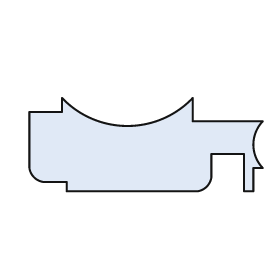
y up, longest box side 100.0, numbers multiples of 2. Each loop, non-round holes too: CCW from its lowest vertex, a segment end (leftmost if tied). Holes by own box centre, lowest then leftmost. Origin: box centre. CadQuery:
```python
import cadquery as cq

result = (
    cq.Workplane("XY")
    .moveTo(-34.0, -20.0)
    .lineTo(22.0, -20.0)
    .threePointArc((26.0, -18.0), (28.0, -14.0))
    .lineTo(28.0, -4.0)
    .lineTo(42.0, -4.0)
    .lineTo(42.0, -20.0)
    .lineTo(46.0, -20.0)
    .lineTo(46.0, -10.0)
    .lineTo(50.0, -10.0)
    .threePointArc((46.0, 0.0), (50.0, 10.0))
    .lineTo(20.0, 10.0)
    .lineTo(20.0, 20.0)
    .threePointArc((-8.0, 8.0), (-36.0, 20.0))
    .lineTo(-36.0, 14.0)
    .lineTo(-50.0, 14.0)
    .lineTo(-50.0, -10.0)
    .threePointArc((-48.0, -14.0), (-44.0, -16.0))
    .lineTo(-34.0, -16.0)
    .close()
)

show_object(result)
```